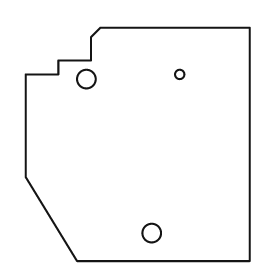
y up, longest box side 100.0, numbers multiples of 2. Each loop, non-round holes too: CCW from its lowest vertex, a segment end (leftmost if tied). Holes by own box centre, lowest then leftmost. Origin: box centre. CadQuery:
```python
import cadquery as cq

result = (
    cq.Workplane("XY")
    .moveTo(-26.0, -50.0)
    .lineTo(48.0, -50.0)
    .lineTo(48.0, 50.0)
    .lineTo(-16.0, 50.0)
    .lineTo(-20.0, 46.0)
    .lineTo(-20.0, 36.0)
    .lineTo(-34.0, 36.0)
    .lineTo(-34.0, 30.0)
    .lineTo(-48.0, 30.0)
    .lineTo(-48.0, -14.0)
    .close()
    .moveTo(6.0, -38.0)
    .circle(4.0)
    .moveTo(-22.0, 28.0)
    .circle(4.0)
    .moveTo(18.0, 30.0)
    .circle(2.0)
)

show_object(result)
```